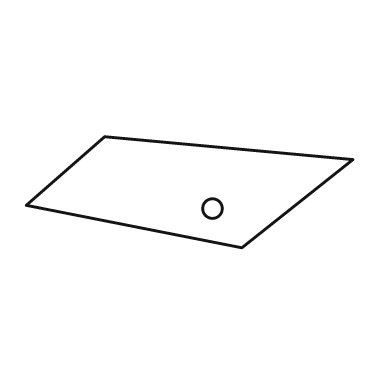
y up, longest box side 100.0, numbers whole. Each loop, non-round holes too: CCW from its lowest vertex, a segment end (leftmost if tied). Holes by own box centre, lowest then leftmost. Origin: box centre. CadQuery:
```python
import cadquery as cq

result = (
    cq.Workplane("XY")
    .moveTo(16.0, -17.0)
    .lineTo(50.0, 10.0)
    .lineTo(-26.0, 17.0)
    .lineTo(-50.0, -4.0)
    .close()
    .moveTo(7.0, -5.0)
    .circle(3.0)
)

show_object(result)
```